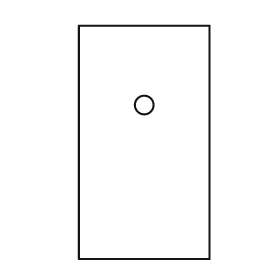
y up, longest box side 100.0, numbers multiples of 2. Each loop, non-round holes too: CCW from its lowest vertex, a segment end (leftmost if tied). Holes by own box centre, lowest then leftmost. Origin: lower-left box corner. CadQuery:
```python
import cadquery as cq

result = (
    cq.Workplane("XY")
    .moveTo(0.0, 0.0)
    .lineTo(56.0, 0.0)
    .lineTo(56.0, 100.0)
    .lineTo(0.0, 100.0)
    .close()
    .moveTo(28.0, 66.0)
    .circle(4.0)
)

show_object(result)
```